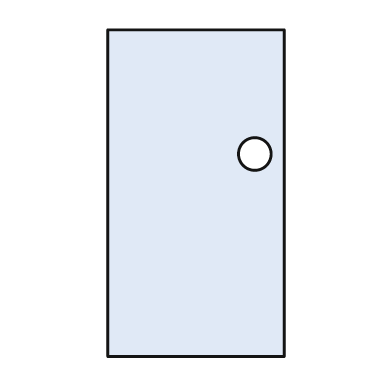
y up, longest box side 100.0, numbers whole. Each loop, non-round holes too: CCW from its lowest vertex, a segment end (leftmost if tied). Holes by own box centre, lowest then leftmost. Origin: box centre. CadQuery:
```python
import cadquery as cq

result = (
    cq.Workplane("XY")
    .moveTo(-27.0, -50.0)
    .lineTo(27.0, -50.0)
    .lineTo(27.0, 50.0)
    .lineTo(-27.0, 50.0)
    .close()
    .moveTo(18.0, 12.0)
    .circle(5.0)
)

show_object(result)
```